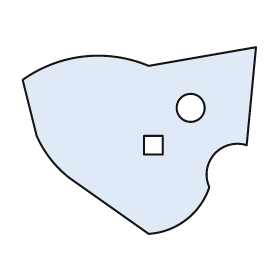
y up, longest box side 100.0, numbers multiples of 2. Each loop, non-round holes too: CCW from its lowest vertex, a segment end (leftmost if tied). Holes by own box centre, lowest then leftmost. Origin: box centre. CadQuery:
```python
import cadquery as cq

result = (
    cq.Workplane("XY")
    .moveTo(4.0, -40.0)
    .threePointArc((20.0, -34.0), (30.0, -20.0))
    .threePointArc((32.0, -6.0), (46.0, -2.0))
    .lineTo(50.0, 40.0)
    .lineTo(4.0, 32.0)
    .threePointArc((-24.0, 36.0), (-50.0, 26.0))
    .lineTo(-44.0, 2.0)
    .threePointArc((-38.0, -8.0), (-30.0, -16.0))
    .close()
    .moveTo(2.0, -6.0)
    .lineTo(10.0, -6.0)
    .lineTo(10.0, 2.0)
    .lineTo(2.0, 2.0)
    .close()
    .moveTo(22.0, 14.0)
    .circle(6.0)
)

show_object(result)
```